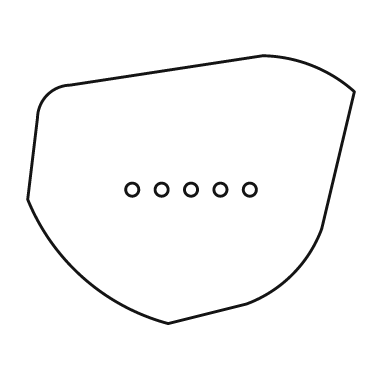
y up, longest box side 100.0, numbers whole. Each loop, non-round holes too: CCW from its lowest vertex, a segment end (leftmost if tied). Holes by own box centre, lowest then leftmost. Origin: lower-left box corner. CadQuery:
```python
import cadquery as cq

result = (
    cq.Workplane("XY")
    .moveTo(43.0, 0.0)
    .lineTo(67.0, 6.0)
    .threePointArc((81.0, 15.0), (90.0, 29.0))
    .lineTo(100.0, 71.0)
    .threePointArc((87.0, 79.0), (72.0, 82.0))
    .lineTo(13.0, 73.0)
    .threePointArc((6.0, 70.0), (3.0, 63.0))
    .lineTo(0.0, 38.0)
    .threePointArc((17.0, 14.0), (43.0, 0.0))
    .close()
    .moveTo(32.0, 41.0)
    .circle(2.0)
    .moveTo(41.0, 41.0)
    .circle(2.0)
    .moveTo(50.0, 41.0)
    .circle(2.0)
    .moveTo(59.0, 41.0)
    .circle(2.0)
    .moveTo(68.0, 41.0)
    .circle(2.0)
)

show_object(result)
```